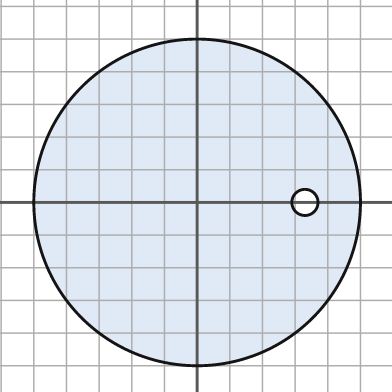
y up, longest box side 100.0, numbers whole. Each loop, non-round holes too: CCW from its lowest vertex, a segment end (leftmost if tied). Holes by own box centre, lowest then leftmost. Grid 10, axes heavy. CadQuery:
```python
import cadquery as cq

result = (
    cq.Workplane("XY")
    .moveTo(0.0, 0.0)
    .circle(50.0)
    .moveTo(33.0, 0.0)
    .circle(4.0)
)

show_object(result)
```